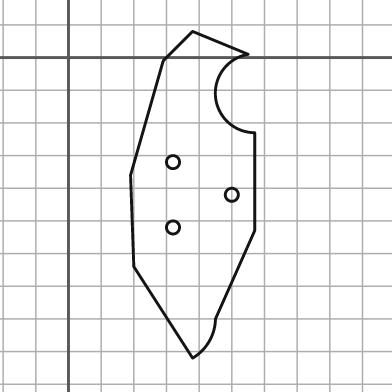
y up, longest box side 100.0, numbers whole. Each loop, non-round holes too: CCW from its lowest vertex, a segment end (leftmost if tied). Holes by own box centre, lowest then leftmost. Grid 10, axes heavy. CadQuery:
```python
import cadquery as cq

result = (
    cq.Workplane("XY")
    .moveTo(38.0, -92.0)
    .threePointArc((43.0, -87.0), (45.0, -80.0))
    .lineTo(57.0, -53.0)
    .lineTo(57.0, -23.0)
    .threePointArc((45.0, -12.0), (55.0, 1.0))
    .lineTo(38.0, 8.0)
    .lineTo(29.0, -1.0)
    .lineTo(19.0, -36.0)
    .lineTo(20.0, -64.0)
    .close()
    .moveTo(32.0, -52.0)
    .circle(2.0)
    .moveTo(50.0, -42.0)
    .circle(2.0)
    .moveTo(32.0, -32.0)
    .circle(2.0)
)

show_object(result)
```